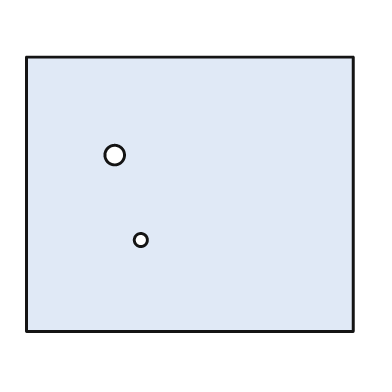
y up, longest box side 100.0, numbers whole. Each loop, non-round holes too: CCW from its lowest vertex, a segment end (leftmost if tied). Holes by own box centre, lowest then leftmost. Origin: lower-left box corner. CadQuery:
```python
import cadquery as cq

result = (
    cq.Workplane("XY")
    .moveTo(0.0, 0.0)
    .lineTo(100.0, 0.0)
    .lineTo(100.0, 84.0)
    .lineTo(0.0, 84.0)
    .close()
    .moveTo(35.0, 28.0)
    .circle(2.0)
    .moveTo(27.0, 54.0)
    .circle(3.0)
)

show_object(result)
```